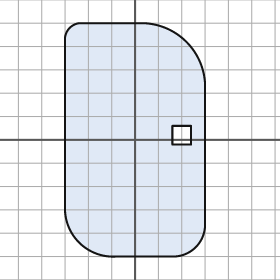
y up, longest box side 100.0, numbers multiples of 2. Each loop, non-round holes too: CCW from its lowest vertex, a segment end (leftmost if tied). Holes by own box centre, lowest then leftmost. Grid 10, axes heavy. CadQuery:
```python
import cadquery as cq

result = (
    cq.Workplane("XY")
    .moveTo(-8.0, -50.0)
    .lineTo(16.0, -50.0)
    .threePointArc((26.0, -46.0), (30.0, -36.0))
    .lineTo(30.0, 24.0)
    .threePointArc((22.0, 42.0), (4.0, 50.0))
    .lineTo(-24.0, 50.0)
    .threePointArc((-28.0, 48.0), (-30.0, 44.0))
    .lineTo(-30.0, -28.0)
    .threePointArc((-24.0, -44.0), (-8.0, -50.0))
    .close()
    .moveTo(16.0, -2.0)
    .lineTo(24.0, -2.0)
    .lineTo(24.0, 6.0)
    .lineTo(16.0, 6.0)
    .close()
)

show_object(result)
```